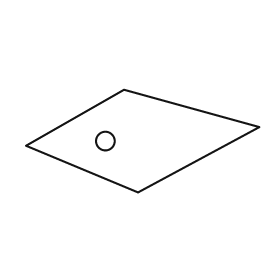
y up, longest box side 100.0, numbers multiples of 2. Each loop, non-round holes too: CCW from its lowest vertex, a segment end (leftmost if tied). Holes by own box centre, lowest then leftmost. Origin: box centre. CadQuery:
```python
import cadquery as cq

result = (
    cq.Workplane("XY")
    .moveTo(-2.0, -22.0)
    .lineTo(50.0, 6.0)
    .lineTo(-8.0, 22.0)
    .lineTo(-50.0, -2.0)
    .close()
    .moveTo(-16.0, 0.0)
    .circle(4.0)
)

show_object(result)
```